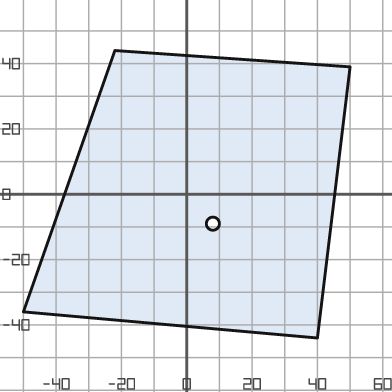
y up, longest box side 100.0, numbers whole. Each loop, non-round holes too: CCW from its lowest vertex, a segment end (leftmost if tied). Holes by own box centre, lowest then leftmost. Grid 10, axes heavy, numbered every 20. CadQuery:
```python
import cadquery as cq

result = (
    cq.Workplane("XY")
    .moveTo(40.0, -44.0)
    .lineTo(50.0, 39.0)
    .lineTo(-22.0, 44.0)
    .lineTo(-50.0, -36.0)
    .close()
    .moveTo(8.0, -9.0)
    .circle(2.0)
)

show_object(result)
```